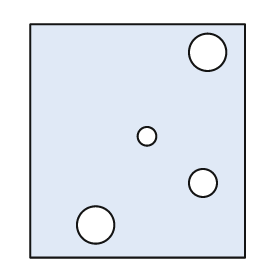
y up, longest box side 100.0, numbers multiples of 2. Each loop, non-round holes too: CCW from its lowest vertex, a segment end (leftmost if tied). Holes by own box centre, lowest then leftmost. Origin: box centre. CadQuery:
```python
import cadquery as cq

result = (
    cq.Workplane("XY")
    .moveTo(-46.0, -50.0)
    .lineTo(46.0, -50.0)
    .lineTo(46.0, 50.0)
    .lineTo(-46.0, 50.0)
    .close()
    .moveTo(-18.0, -36.0)
    .circle(8.0)
    .moveTo(28.0, -18.0)
    .circle(6.0)
    .moveTo(4.0, 2.0)
    .circle(4.0)
    .moveTo(30.0, 38.0)
    .circle(8.0)
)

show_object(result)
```